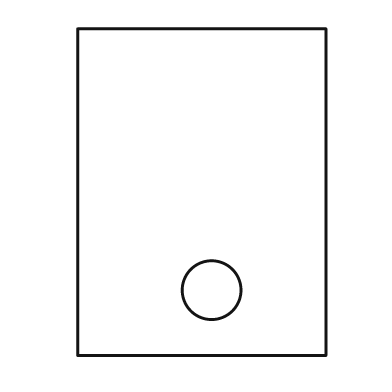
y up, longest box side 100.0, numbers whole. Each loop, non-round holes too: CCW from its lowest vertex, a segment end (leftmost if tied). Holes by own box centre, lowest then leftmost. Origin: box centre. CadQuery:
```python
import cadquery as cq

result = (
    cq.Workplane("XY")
    .moveTo(-38.0, -50.0)
    .lineTo(38.0, -50.0)
    .lineTo(38.0, 50.0)
    .lineTo(-38.0, 50.0)
    .close()
    .moveTo(3.0, -30.0)
    .circle(9.0)
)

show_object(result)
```